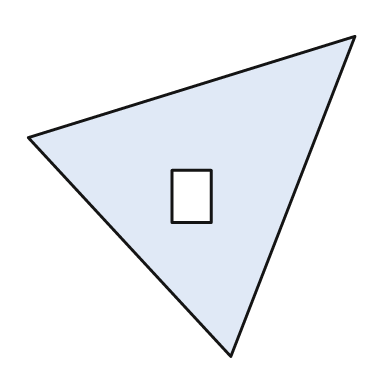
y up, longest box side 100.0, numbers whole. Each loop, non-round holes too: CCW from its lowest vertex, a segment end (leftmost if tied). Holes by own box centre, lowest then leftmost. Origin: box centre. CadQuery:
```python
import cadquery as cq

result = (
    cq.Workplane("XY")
    .moveTo(12.0, -49.0)
    .lineTo(50.0, 49.0)
    .lineTo(-50.0, 18.0)
    .close()
    .moveTo(-6.0, -8.0)
    .lineTo(6.0, -8.0)
    .lineTo(6.0, 8.0)
    .lineTo(-6.0, 8.0)
    .close()
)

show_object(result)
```